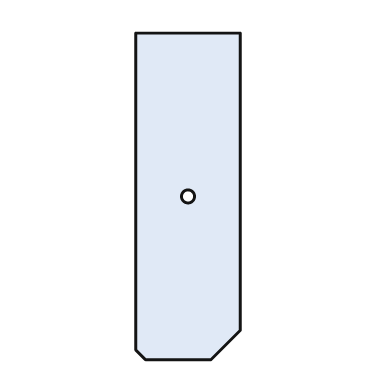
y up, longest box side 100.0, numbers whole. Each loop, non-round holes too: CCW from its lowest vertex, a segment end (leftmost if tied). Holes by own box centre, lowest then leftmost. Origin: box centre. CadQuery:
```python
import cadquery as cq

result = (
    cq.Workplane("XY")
    .moveTo(-13.0, -50.0)
    .lineTo(7.0, -50.0)
    .lineTo(16.0, -41.0)
    .lineTo(16.0, 50.0)
    .lineTo(-16.0, 50.0)
    .lineTo(-16.0, -47.0)
    .close()
    .moveTo(0.0, 0.0)
    .circle(2.0)
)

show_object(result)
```